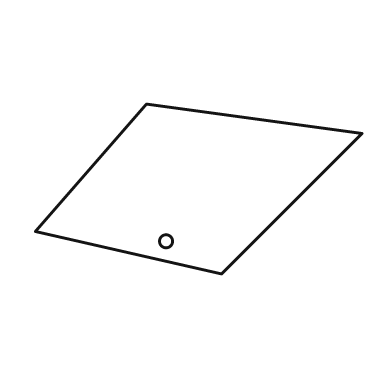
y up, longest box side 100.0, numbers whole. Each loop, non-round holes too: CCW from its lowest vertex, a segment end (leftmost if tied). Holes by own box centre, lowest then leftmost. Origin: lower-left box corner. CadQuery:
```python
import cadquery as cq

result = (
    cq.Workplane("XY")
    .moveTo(57.0, 0.0)
    .lineTo(100.0, 43.0)
    .lineTo(34.0, 52.0)
    .lineTo(0.0, 13.0)
    .close()
    .moveTo(40.0, 10.0)
    .circle(2.0)
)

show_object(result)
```